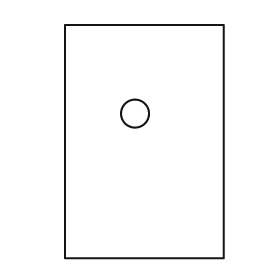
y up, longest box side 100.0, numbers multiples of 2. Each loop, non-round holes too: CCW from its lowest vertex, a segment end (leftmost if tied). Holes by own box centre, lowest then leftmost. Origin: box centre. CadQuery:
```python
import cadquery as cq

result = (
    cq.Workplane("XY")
    .moveTo(-34.0, -50.0)
    .lineTo(34.0, -50.0)
    .lineTo(34.0, 50.0)
    .lineTo(-34.0, 50.0)
    .close()
    .moveTo(-4.0, 12.0)
    .circle(6.0)
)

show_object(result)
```